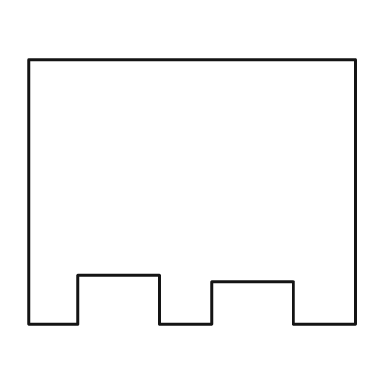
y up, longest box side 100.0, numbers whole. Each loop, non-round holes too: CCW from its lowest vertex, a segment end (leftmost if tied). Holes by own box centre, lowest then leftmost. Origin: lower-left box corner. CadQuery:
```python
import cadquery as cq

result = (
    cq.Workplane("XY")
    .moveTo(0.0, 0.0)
    .lineTo(15.0, 0.0)
    .lineTo(15.0, 15.0)
    .lineTo(40.0, 15.0)
    .lineTo(40.0, 0.0)
    .lineTo(56.0, 0.0)
    .lineTo(56.0, 13.0)
    .lineTo(81.0, 13.0)
    .lineTo(81.0, 0.0)
    .lineTo(100.0, 0.0)
    .lineTo(100.0, 81.0)
    .lineTo(0.0, 81.0)
    .close()
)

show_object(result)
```